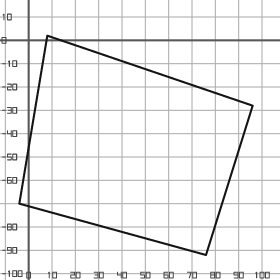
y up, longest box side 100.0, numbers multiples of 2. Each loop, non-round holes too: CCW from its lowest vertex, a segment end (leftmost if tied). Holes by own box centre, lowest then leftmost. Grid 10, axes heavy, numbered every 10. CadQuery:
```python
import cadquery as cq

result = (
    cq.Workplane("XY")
    .moveTo(76.0, -92.0)
    .lineTo(96.0, -28.0)
    .lineTo(8.0, 2.0)
    .lineTo(-4.0, -70.0)
    .close()
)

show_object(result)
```